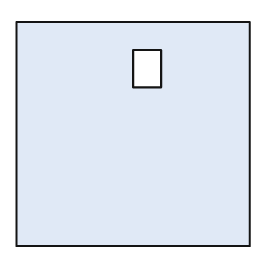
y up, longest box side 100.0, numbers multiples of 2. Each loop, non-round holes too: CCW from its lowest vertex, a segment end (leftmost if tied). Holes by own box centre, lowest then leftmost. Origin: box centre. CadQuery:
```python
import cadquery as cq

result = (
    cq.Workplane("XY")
    .moveTo(-50.0, -48.0)
    .lineTo(50.0, -48.0)
    .lineTo(50.0, 48.0)
    .lineTo(-50.0, 48.0)
    .close()
    .moveTo(0.0, 20.0)
    .lineTo(12.0, 20.0)
    .lineTo(12.0, 36.0)
    .lineTo(0.0, 36.0)
    .close()
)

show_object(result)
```